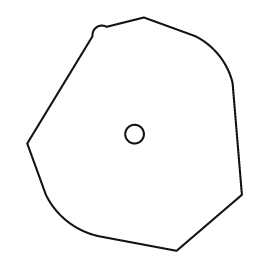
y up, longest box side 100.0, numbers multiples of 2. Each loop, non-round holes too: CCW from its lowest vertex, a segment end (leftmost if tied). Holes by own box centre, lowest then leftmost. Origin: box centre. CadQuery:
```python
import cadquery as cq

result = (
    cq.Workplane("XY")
    .moveTo(18.0, -50.0)
    .lineTo(46.0, -26.0)
    .lineTo(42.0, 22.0)
    .threePointArc((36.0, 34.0), (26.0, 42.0))
    .lineTo(4.0, 50.0)
    .lineTo(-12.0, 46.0)
    .threePointArc((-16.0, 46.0), (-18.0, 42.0))
    .lineTo(-46.0, -4.0)
    .lineTo(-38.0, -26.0)
    .threePointArc((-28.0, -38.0), (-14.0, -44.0))
    .close()
    .moveTo(0.0, 0.0)
    .circle(4.0)
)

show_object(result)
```